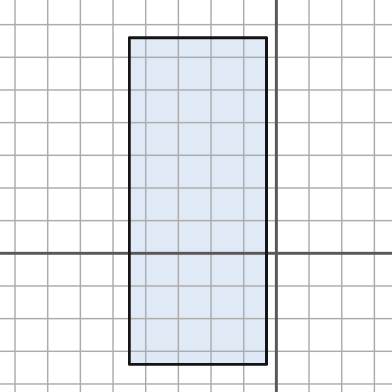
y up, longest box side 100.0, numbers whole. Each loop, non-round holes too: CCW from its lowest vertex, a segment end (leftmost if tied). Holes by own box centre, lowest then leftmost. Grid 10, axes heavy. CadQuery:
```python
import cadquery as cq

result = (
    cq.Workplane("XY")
    .moveTo(-45.0, -34.0)
    .lineTo(-3.0, -34.0)
    .lineTo(-3.0, 66.0)
    .lineTo(-45.0, 66.0)
    .close()
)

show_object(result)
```